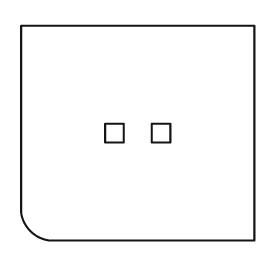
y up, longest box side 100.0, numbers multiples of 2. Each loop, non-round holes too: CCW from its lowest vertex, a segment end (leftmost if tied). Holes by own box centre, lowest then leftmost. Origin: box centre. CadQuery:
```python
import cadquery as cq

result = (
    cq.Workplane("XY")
    .moveTo(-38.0, -46.0)
    .lineTo(50.0, -46.0)
    .lineTo(50.0, 46.0)
    .lineTo(-50.0, 46.0)
    .lineTo(-50.0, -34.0)
    .threePointArc((-46.0, -42.0), (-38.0, -46.0))
    .close()
    .moveTo(-14.0, -4.0)
    .lineTo(-6.0, -4.0)
    .lineTo(-6.0, 4.0)
    .lineTo(-14.0, 4.0)
    .close()
    .moveTo(6.0, -4.0)
    .lineTo(14.0, -4.0)
    .lineTo(14.0, 4.0)
    .lineTo(6.0, 4.0)
    .close()
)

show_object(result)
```